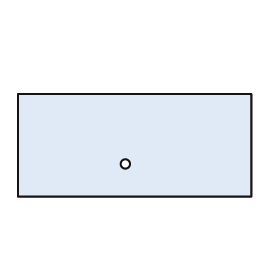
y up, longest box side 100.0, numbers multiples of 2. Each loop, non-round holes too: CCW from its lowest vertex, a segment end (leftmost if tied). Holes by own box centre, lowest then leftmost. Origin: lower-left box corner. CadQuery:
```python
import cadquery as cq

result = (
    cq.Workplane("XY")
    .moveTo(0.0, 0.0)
    .lineTo(100.0, 0.0)
    .lineTo(100.0, 44.0)
    .lineTo(0.0, 44.0)
    .close()
    .moveTo(46.0, 14.0)
    .circle(2.0)
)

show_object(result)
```